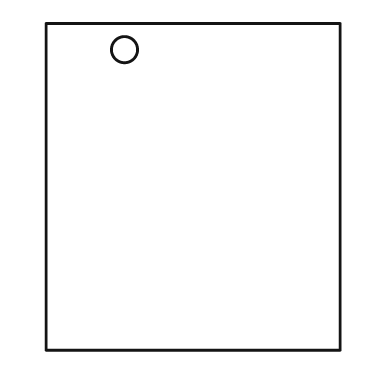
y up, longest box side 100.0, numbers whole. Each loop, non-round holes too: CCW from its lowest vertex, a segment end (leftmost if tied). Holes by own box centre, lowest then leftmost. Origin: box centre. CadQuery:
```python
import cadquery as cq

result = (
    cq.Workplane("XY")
    .moveTo(-45.0, -50.0)
    .lineTo(45.0, -50.0)
    .lineTo(45.0, 50.0)
    .lineTo(-45.0, 50.0)
    .close()
    .moveTo(-21.0, 42.0)
    .circle(4.0)
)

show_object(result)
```